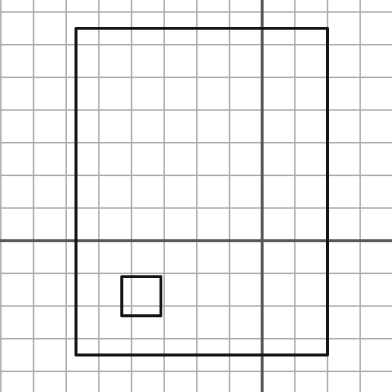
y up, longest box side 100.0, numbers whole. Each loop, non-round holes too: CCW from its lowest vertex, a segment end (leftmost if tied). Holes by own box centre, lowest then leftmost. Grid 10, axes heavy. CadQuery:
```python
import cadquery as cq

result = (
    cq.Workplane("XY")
    .moveTo(-57.0, -35.0)
    .lineTo(20.0, -35.0)
    .lineTo(20.0, 65.0)
    .lineTo(-57.0, 65.0)
    .close()
    .moveTo(-43.0, -23.0)
    .lineTo(-31.0, -23.0)
    .lineTo(-31.0, -11.0)
    .lineTo(-43.0, -11.0)
    .close()
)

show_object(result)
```